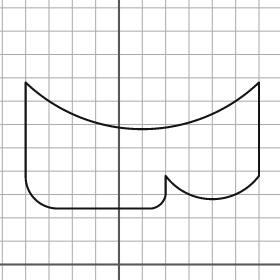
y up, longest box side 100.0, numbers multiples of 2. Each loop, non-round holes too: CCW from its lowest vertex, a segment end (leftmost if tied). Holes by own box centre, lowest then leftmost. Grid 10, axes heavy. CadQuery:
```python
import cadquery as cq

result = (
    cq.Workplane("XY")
    .moveTo(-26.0, 24.0)
    .lineTo(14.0, 24.0)
    .threePointArc((18.0, 26.0), (20.0, 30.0))
    .lineTo(20.0, 38.0)
    .threePointArc((40.0, 28.0), (60.0, 38.0))
    .lineTo(60.0, 78.0)
    .threePointArc((10.0, 58.0), (-40.0, 78.0))
    .lineTo(-40.0, 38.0)
    .threePointArc((-36.0, 28.0), (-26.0, 24.0))
    .close()
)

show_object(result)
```